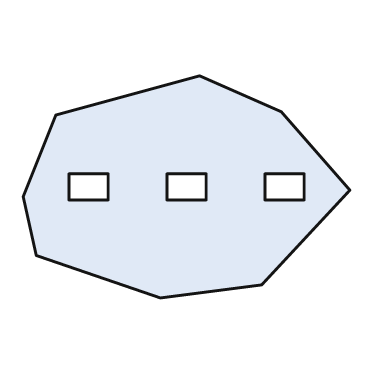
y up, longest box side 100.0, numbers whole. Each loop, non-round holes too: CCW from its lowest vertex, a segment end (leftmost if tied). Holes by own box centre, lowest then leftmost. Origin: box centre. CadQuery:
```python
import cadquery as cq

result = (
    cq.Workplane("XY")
    .moveTo(-8.0, -34.0)
    .lineTo(23.0, -30.0)
    .lineTo(50.0, -1.0)
    .lineTo(29.0, 23.0)
    .lineTo(4.0, 34.0)
    .lineTo(-40.0, 22.0)
    .lineTo(-50.0, -3.0)
    .lineTo(-46.0, -21.0)
    .close()
    .moveTo(-36.0, -4.0)
    .lineTo(-24.0, -4.0)
    .lineTo(-24.0, 4.0)
    .lineTo(-36.0, 4.0)
    .close()
    .moveTo(-6.0, -4.0)
    .lineTo(6.0, -4.0)
    .lineTo(6.0, 4.0)
    .lineTo(-6.0, 4.0)
    .close()
    .moveTo(24.0, -4.0)
    .lineTo(36.0, -4.0)
    .lineTo(36.0, 4.0)
    .lineTo(24.0, 4.0)
    .close()
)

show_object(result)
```